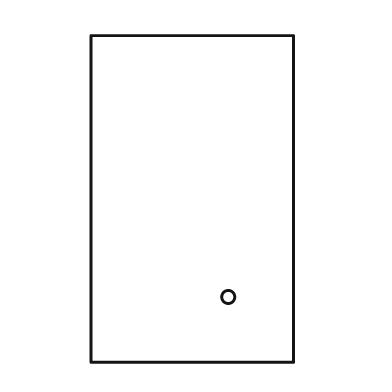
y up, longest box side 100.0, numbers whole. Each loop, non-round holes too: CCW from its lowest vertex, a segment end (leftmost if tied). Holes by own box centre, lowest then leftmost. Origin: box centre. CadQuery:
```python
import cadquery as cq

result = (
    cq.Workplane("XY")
    .moveTo(-31.0, -50.0)
    .lineTo(31.0, -50.0)
    .lineTo(31.0, 50.0)
    .lineTo(-31.0, 50.0)
    .close()
    .moveTo(11.0, -30.0)
    .circle(2.0)
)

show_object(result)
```